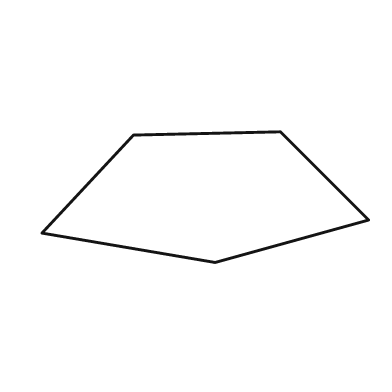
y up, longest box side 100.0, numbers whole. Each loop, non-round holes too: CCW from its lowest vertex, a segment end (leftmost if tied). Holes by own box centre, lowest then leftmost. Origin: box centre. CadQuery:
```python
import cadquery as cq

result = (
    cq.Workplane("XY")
    .moveTo(3.0, -20.0)
    .lineTo(50.0, -7.0)
    .lineTo(23.0, 20.0)
    .lineTo(-22.0, 19.0)
    .lineTo(-50.0, -11.0)
    .close()
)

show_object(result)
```